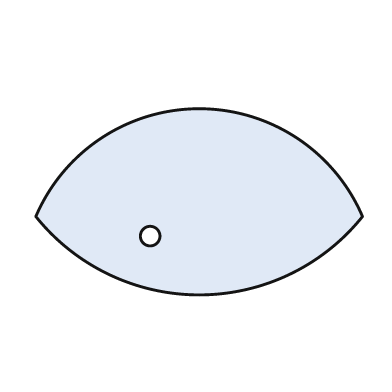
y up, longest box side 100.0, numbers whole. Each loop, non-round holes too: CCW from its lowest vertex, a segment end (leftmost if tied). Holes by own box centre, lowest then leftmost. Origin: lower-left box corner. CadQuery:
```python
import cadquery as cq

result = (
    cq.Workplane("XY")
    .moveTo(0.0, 24.0)
    .threePointArc((50.0, 0.0), (100.0, 24.0))
    .threePointArc((50.0, 57.0), (0.0, 24.0))
    .close()
    .moveTo(35.0, 18.0)
    .circle(3.0)
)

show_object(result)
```